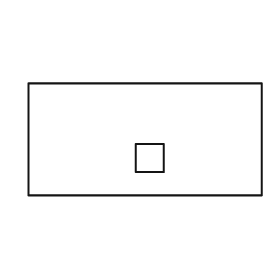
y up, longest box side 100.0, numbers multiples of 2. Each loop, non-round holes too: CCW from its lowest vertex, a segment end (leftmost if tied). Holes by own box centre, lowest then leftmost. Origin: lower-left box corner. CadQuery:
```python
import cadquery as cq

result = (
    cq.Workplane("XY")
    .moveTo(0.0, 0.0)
    .lineTo(100.0, 0.0)
    .lineTo(100.0, 48.0)
    .lineTo(0.0, 48.0)
    .close()
    .moveTo(46.0, 10.0)
    .lineTo(58.0, 10.0)
    .lineTo(58.0, 22.0)
    .lineTo(46.0, 22.0)
    .close()
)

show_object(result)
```